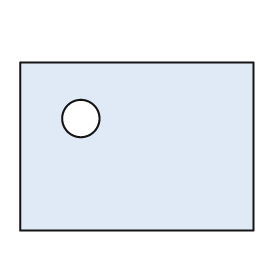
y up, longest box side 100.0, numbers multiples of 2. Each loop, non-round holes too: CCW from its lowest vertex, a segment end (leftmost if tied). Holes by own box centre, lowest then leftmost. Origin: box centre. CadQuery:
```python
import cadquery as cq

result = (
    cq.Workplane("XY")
    .moveTo(-50.0, -36.0)
    .lineTo(50.0, -36.0)
    .lineTo(50.0, 36.0)
    .lineTo(-50.0, 36.0)
    .close()
    .moveTo(-24.0, 12.0)
    .circle(8.0)
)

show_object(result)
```